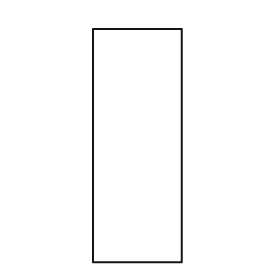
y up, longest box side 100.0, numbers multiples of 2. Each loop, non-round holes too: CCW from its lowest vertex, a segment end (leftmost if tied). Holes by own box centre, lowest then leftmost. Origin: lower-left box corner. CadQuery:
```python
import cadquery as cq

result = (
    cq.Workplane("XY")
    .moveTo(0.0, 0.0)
    .lineTo(38.0, 0.0)
    .lineTo(38.0, 100.0)
    .lineTo(0.0, 100.0)
    .close()
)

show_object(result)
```